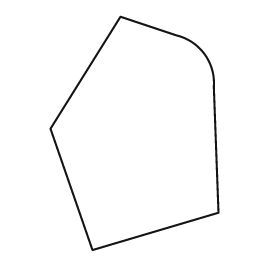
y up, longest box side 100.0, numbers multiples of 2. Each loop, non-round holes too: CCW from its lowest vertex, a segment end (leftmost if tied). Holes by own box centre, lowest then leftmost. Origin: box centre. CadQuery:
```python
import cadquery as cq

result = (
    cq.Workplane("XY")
    .moveTo(-18.0, -50.0)
    .lineTo(36.0, -34.0)
    .lineTo(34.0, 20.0)
    .threePointArc((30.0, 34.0), (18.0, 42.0))
    .lineTo(-6.0, 50.0)
    .lineTo(-36.0, 2.0)
    .close()
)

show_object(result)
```